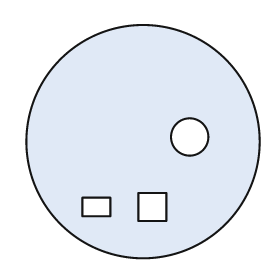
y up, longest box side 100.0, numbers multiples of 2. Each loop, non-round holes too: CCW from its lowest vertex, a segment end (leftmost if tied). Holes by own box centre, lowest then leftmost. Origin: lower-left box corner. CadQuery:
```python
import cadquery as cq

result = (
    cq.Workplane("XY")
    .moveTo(50.0, 50.0)
    .circle(50.0)
    .moveTo(24.0, 18.0)
    .lineTo(36.0, 18.0)
    .lineTo(36.0, 26.0)
    .lineTo(24.0, 26.0)
    .close()
    .moveTo(48.0, 16.0)
    .lineTo(60.0, 16.0)
    .lineTo(60.0, 28.0)
    .lineTo(48.0, 28.0)
    .close()
    .moveTo(70.0, 52.0)
    .circle(8.0)
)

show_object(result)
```